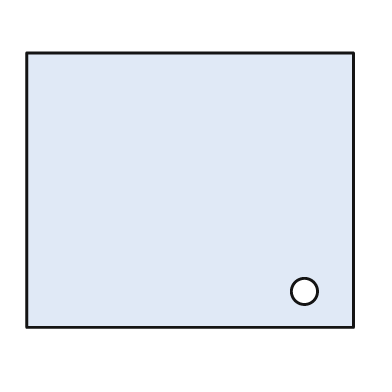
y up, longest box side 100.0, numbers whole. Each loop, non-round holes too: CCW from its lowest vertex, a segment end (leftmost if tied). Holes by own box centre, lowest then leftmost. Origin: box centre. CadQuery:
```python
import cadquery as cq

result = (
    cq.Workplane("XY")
    .moveTo(-50.0, -42.0)
    .lineTo(50.0, -42.0)
    .lineTo(50.0, 42.0)
    .lineTo(-50.0, 42.0)
    .close()
    .moveTo(35.0, -31.0)
    .circle(4.0)
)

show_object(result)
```